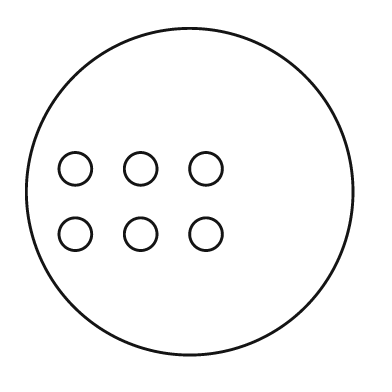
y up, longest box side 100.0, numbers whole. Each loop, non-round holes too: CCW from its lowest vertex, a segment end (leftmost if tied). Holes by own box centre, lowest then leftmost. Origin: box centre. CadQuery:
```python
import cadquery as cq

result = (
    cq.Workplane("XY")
    .moveTo(0.0, 0.0)
    .circle(50.0)
    .moveTo(-35.0, -13.0)
    .circle(5.0)
    .moveTo(-15.0, -13.0)
    .circle(5.0)
    .moveTo(5.0, -13.0)
    .circle(5.0)
    .moveTo(-35.0, 7.0)
    .circle(5.0)
    .moveTo(-15.0, 7.0)
    .circle(5.0)
    .moveTo(5.0, 7.0)
    .circle(5.0)
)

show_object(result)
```